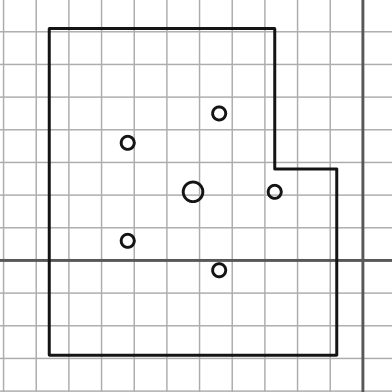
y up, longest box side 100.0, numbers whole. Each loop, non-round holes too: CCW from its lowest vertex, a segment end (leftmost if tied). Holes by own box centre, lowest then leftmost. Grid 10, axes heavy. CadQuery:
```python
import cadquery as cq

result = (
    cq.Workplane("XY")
    .moveTo(-96.0, -29.0)
    .lineTo(-8.0, -29.0)
    .lineTo(-8.0, 28.0)
    .lineTo(-27.0, 28.0)
    .lineTo(-27.0, 71.0)
    .lineTo(-96.0, 71.0)
    .close()
    .moveTo(-44.0, -3.0)
    .circle(2.0)
    .moveTo(-72.0, 6.0)
    .circle(2.0)
    .moveTo(-52.0, 21.0)
    .circle(3.0)
    .moveTo(-27.0, 21.0)
    .circle(2.0)
    .moveTo(-72.0, 36.0)
    .circle(2.0)
    .moveTo(-44.0, 45.0)
    .circle(2.0)
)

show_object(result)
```